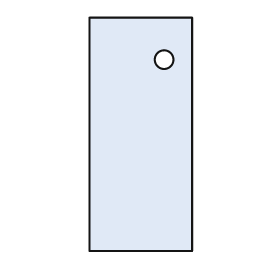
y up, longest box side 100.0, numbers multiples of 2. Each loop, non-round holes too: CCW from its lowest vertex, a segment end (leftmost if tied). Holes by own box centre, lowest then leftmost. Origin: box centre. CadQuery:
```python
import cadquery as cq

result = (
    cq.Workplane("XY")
    .moveTo(-22.0, -50.0)
    .lineTo(22.0, -50.0)
    .lineTo(22.0, 50.0)
    .lineTo(-22.0, 50.0)
    .close()
    .moveTo(10.0, 32.0)
    .circle(4.0)
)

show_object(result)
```